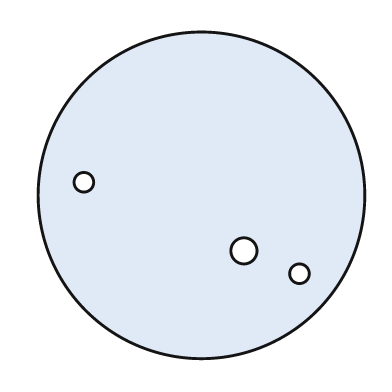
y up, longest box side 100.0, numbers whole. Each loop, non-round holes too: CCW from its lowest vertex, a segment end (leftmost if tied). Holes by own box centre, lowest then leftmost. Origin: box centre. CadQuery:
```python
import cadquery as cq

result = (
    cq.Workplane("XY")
    .moveTo(0.0, 0.0)
    .circle(50.0)
    .moveTo(30.0, -24.0)
    .circle(3.0)
    .moveTo(13.0, -17.0)
    .circle(4.0)
    .moveTo(-36.0, 4.0)
    .circle(3.0)
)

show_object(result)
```